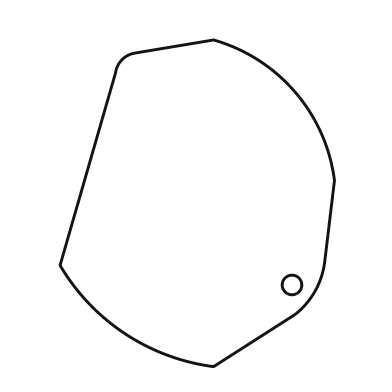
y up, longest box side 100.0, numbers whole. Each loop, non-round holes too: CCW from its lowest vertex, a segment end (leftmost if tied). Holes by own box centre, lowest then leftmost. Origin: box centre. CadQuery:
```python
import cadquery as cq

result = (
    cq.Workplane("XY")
    .moveTo(5.0, -50.0)
    .lineTo(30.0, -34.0)
    .threePointArc((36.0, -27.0), (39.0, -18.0))
    .lineTo(42.0, 7.0)
    .threePointArc((30.0, 34.0), (5.0, 50.0))
    .lineTo(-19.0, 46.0)
    .threePointArc((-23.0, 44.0), (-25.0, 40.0))
    .lineTo(-42.0, -19.0)
    .threePointArc((-22.0, -40.0), (5.0, -50.0))
    .close()
    .moveTo(29.0, -25.0)
    .circle(3.0)
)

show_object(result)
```